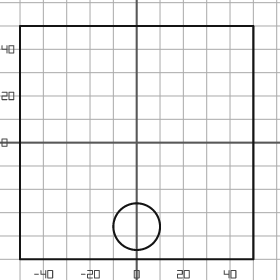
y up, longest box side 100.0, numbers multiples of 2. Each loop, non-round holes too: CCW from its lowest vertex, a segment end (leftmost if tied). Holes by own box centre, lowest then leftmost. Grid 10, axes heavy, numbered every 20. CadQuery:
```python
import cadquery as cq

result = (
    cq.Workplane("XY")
    .moveTo(-50.0, -50.0)
    .lineTo(50.0, -50.0)
    .lineTo(50.0, 50.0)
    .lineTo(-50.0, 50.0)
    .close()
    .moveTo(0.0, -36.0)
    .circle(10.0)
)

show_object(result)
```